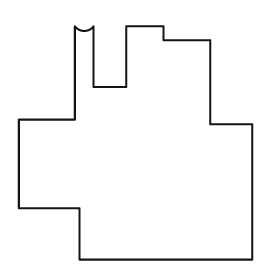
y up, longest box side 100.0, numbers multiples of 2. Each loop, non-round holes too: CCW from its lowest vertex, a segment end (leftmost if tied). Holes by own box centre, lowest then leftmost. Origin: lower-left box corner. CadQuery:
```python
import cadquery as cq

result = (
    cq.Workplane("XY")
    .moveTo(26.0, 0.0)
    .lineTo(100.0, 0.0)
    .lineTo(100.0, 58.0)
    .lineTo(82.0, 58.0)
    .lineTo(82.0, 94.0)
    .lineTo(62.0, 94.0)
    .lineTo(62.0, 100.0)
    .lineTo(46.0, 100.0)
    .lineTo(46.0, 74.0)
    .lineTo(32.0, 74.0)
    .lineTo(32.0, 100.0)
    .threePointArc((28.0, 98.0), (24.0, 100.0))
    .lineTo(24.0, 60.0)
    .lineTo(0.0, 60.0)
    .lineTo(0.0, 22.0)
    .lineTo(26.0, 22.0)
    .close()
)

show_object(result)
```